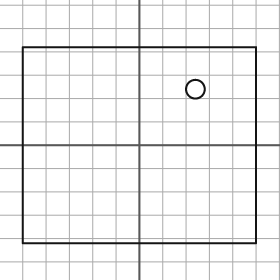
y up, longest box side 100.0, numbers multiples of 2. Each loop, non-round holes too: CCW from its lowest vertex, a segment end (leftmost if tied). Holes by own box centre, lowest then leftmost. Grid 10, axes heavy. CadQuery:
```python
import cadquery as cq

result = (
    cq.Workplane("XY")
    .moveTo(-50.0, -42.0)
    .lineTo(50.0, -42.0)
    .lineTo(50.0, 42.0)
    .lineTo(-50.0, 42.0)
    .close()
    .moveTo(24.0, 24.0)
    .circle(4.0)
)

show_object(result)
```